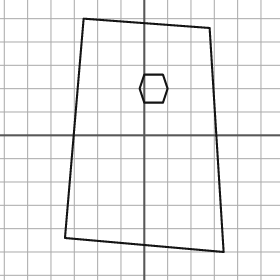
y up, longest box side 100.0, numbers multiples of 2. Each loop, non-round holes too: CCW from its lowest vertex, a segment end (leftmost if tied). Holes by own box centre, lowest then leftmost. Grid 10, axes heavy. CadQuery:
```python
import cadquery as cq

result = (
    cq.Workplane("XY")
    .moveTo(34.0, -50.0)
    .lineTo(28.0, 46.0)
    .lineTo(-26.0, 50.0)
    .lineTo(-34.0, -44.0)
    .close()
    .moveTo(0.0, 14.0)
    .lineTo(8.0, 14.0)
    .lineTo(10.0, 20.0)
    .lineTo(8.0, 26.0)
    .lineTo(0.0, 26.0)
    .lineTo(-2.0, 20.0)
    .close()
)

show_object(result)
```